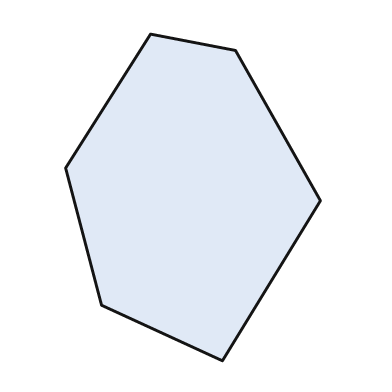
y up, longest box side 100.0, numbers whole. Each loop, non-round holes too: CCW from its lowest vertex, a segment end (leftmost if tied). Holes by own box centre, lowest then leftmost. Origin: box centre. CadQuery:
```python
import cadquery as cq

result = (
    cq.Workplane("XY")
    .moveTo(9.0, -50.0)
    .lineTo(39.0, -1.0)
    .lineTo(13.0, 45.0)
    .lineTo(-13.0, 50.0)
    .lineTo(-39.0, 9.0)
    .lineTo(-28.0, -33.0)
    .close()
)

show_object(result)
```